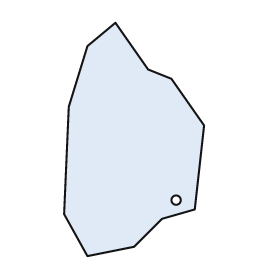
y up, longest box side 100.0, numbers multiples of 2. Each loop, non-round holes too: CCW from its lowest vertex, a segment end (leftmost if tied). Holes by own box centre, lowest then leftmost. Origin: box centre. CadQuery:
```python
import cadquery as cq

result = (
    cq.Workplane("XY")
    .moveTo(-20.0, -50.0)
    .lineTo(0.0, -46.0)
    .lineTo(12.0, -34.0)
    .lineTo(26.0, -30.0)
    .lineTo(30.0, 6.0)
    .lineTo(16.0, 26.0)
    .lineTo(6.0, 30.0)
    .lineTo(-8.0, 50.0)
    .lineTo(-20.0, 40.0)
    .lineTo(-28.0, 14.0)
    .lineTo(-30.0, -32.0)
    .close()
    .moveTo(18.0, -26.0)
    .circle(2.0)
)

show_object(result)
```